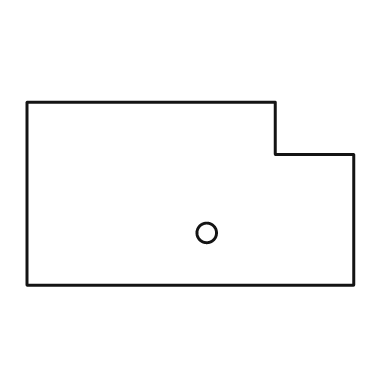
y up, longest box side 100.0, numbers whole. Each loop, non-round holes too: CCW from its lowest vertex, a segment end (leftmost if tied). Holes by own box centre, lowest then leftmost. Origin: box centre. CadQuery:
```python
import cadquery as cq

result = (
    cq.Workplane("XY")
    .moveTo(-50.0, -28.0)
    .lineTo(50.0, -28.0)
    .lineTo(50.0, 12.0)
    .lineTo(26.0, 12.0)
    .lineTo(26.0, 28.0)
    .lineTo(-50.0, 28.0)
    .close()
    .moveTo(5.0, -12.0)
    .circle(3.0)
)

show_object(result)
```